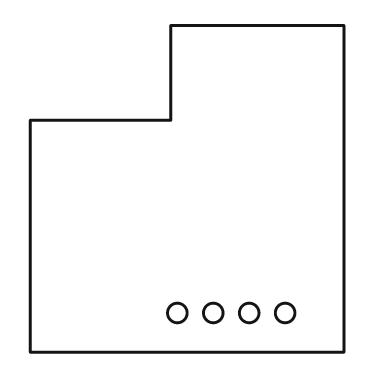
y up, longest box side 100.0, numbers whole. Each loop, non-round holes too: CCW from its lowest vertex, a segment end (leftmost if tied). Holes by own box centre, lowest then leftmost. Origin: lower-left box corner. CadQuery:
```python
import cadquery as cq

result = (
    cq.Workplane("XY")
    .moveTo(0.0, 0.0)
    .lineTo(96.0, 0.0)
    .lineTo(96.0, 100.0)
    .lineTo(43.0, 100.0)
    .lineTo(43.0, 71.0)
    .lineTo(0.0, 71.0)
    .close()
    .moveTo(45.0, 12.0)
    .circle(3.0)
    .moveTo(56.0, 12.0)
    .circle(3.0)
    .moveTo(67.0, 12.0)
    .circle(3.0)
    .moveTo(78.0, 12.0)
    .circle(3.0)
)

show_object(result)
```